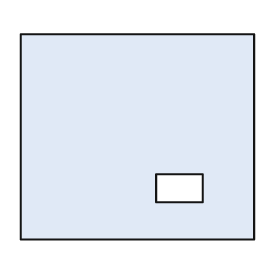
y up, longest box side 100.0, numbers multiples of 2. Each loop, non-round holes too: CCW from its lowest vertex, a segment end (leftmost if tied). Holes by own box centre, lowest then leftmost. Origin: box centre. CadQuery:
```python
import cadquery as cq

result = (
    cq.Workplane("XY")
    .moveTo(-50.0, -44.0)
    .lineTo(50.0, -44.0)
    .lineTo(50.0, 44.0)
    .lineTo(-50.0, 44.0)
    .close()
    .moveTo(8.0, -28.0)
    .lineTo(28.0, -28.0)
    .lineTo(28.0, -16.0)
    .lineTo(8.0, -16.0)
    .close()
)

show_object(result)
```